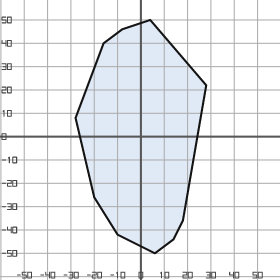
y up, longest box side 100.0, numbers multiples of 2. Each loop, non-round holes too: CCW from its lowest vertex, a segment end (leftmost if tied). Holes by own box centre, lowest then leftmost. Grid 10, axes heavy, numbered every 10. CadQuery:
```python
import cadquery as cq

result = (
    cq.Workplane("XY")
    .moveTo(6.0, -50.0)
    .lineTo(14.0, -44.0)
    .lineTo(18.0, -36.0)
    .lineTo(28.0, 22.0)
    .lineTo(4.0, 50.0)
    .lineTo(-8.0, 46.0)
    .lineTo(-16.0, 40.0)
    .lineTo(-28.0, 8.0)
    .lineTo(-20.0, -26.0)
    .lineTo(-10.0, -42.0)
    .close()
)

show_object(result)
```